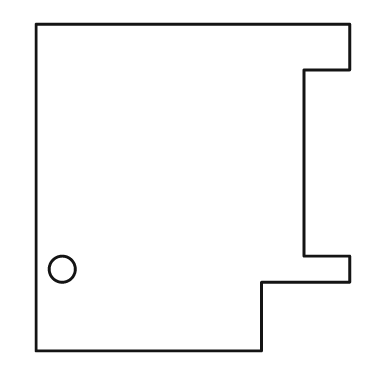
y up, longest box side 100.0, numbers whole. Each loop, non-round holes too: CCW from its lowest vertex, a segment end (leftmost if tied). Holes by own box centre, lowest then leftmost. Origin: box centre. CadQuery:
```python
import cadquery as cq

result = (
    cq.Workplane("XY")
    .moveTo(-48.0, -50.0)
    .lineTo(21.0, -50.0)
    .lineTo(21.0, -29.0)
    .lineTo(48.0, -29.0)
    .lineTo(48.0, -21.0)
    .lineTo(34.0, -21.0)
    .lineTo(34.0, 36.0)
    .lineTo(48.0, 36.0)
    .lineTo(48.0, 50.0)
    .lineTo(-48.0, 50.0)
    .close()
    .moveTo(-40.0, -25.0)
    .circle(4.0)
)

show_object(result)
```